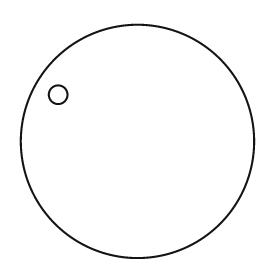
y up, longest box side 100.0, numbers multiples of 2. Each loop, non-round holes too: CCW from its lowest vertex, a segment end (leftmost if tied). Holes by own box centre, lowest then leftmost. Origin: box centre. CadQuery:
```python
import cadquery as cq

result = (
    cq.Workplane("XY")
    .moveTo(0.0, 0.0)
    .circle(50.0)
    .moveTo(-34.0, 20.0)
    .circle(4.0)
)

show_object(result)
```